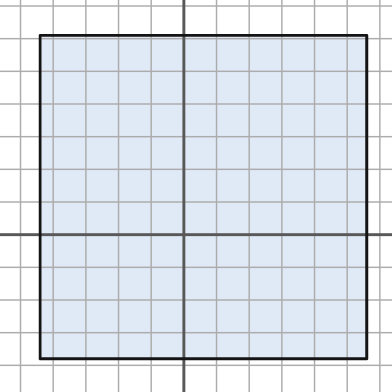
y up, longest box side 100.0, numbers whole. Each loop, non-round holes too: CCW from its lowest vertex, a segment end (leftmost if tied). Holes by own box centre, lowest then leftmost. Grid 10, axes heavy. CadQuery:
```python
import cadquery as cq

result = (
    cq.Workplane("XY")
    .moveTo(-44.0, -38.0)
    .lineTo(56.0, -38.0)
    .lineTo(56.0, 61.0)
    .lineTo(-44.0, 61.0)
    .close()
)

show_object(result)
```